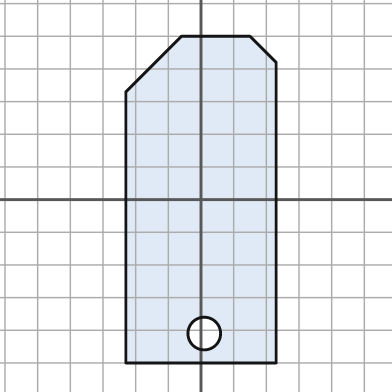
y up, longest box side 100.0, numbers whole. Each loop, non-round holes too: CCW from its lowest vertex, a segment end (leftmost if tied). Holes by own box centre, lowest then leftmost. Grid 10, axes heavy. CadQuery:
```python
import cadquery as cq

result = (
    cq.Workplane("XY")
    .moveTo(-23.0, -50.0)
    .lineTo(23.0, -50.0)
    .lineTo(23.0, 42.0)
    .lineTo(15.0, 50.0)
    .lineTo(-6.0, 50.0)
    .lineTo(-23.0, 33.0)
    .close()
    .moveTo(1.0, -41.0)
    .circle(5.0)
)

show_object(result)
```